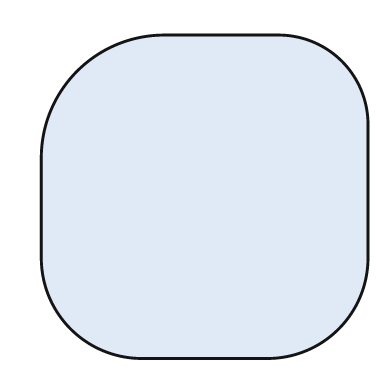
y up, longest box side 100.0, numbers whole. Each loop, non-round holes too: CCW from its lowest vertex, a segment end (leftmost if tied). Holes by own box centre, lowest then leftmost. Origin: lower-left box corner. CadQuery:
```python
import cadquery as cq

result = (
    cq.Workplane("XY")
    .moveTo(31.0, 0.0)
    .lineTo(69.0, 0.0)
    .threePointArc((91.0, 9.0), (100.0, 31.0))
    .lineTo(100.0, 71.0)
    .threePointArc((92.0, 91.0), (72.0, 99.0))
    .lineTo(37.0, 99.0)
    .threePointArc((11.0, 88.0), (0.0, 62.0))
    .lineTo(0.0, 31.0)
    .threePointArc((9.0, 9.0), (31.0, 0.0))
    .close()
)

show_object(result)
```